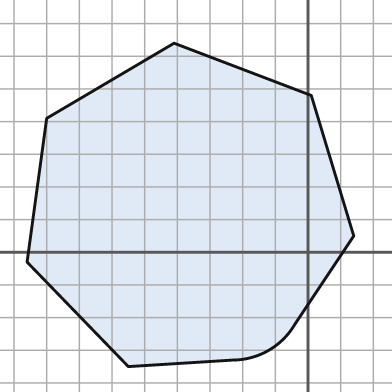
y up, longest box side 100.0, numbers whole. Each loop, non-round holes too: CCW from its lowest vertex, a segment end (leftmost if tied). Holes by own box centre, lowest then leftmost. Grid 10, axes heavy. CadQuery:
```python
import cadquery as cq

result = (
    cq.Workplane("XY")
    .moveTo(-55.0, -35.0)
    .lineTo(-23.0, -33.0)
    .threePointArc((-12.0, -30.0), (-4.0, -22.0))
    .lineTo(14.0, 5.0)
    .lineTo(1.0, 48.0)
    .lineTo(-41.0, 64.0)
    .lineTo(-80.0, 41.0)
    .lineTo(-86.0, -3.0)
    .close()
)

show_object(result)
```